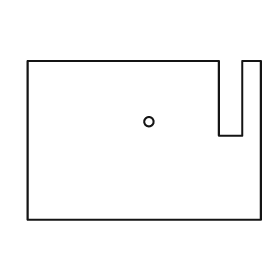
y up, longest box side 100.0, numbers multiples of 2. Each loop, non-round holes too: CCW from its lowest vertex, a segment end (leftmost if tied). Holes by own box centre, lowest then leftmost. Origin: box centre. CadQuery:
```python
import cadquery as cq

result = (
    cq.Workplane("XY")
    .moveTo(-50.0, -34.0)
    .lineTo(50.0, -34.0)
    .lineTo(50.0, 34.0)
    .lineTo(42.0, 34.0)
    .lineTo(42.0, 2.0)
    .lineTo(32.0, 2.0)
    .lineTo(32.0, 34.0)
    .lineTo(-50.0, 34.0)
    .close()
    .moveTo(2.0, 8.0)
    .circle(2.0)
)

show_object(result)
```